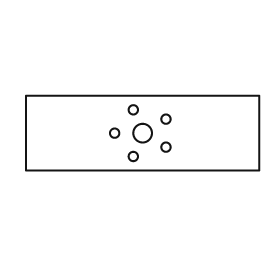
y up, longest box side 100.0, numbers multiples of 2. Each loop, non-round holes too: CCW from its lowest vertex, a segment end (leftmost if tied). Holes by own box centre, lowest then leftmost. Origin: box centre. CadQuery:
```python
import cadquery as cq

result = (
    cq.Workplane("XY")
    .moveTo(-50.0, -16.0)
    .lineTo(50.0, -16.0)
    .lineTo(50.0, 16.0)
    .lineTo(-50.0, 16.0)
    .close()
    .moveTo(-4.0, -10.0)
    .circle(2.0)
    .moveTo(10.0, -6.0)
    .circle(2.0)
    .moveTo(-12.0, 0.0)
    .circle(2.0)
    .moveTo(0.0, 0.0)
    .circle(4.0)
    .moveTo(10.0, 6.0)
    .circle(2.0)
    .moveTo(-4.0, 10.0)
    .circle(2.0)
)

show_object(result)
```